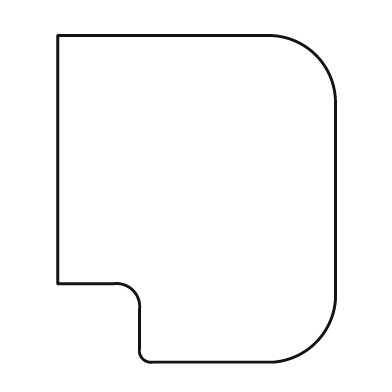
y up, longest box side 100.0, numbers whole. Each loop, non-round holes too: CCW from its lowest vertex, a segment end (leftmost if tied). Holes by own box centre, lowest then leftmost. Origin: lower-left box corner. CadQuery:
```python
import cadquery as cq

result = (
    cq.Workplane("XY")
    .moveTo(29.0, 0.0)
    .lineTo(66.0, 0.0)
    .threePointArc((79.0, 6.0), (85.0, 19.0))
    .lineTo(85.0, 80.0)
    .threePointArc((79.0, 94.0), (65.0, 100.0))
    .lineTo(0.0, 100.0)
    .lineTo(0.0, 24.0)
    .lineTo(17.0, 24.0)
    .threePointArc((23.0, 22.0), (25.0, 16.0))
    .lineTo(25.0, 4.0)
    .threePointArc((26.0, 1.0), (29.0, 0.0))
    .close()
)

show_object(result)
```